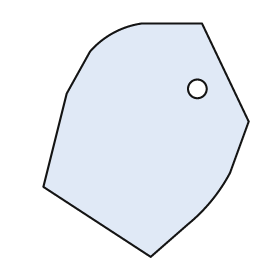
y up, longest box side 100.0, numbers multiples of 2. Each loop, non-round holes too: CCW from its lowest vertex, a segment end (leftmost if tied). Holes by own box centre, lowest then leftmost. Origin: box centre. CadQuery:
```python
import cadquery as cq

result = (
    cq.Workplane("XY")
    .moveTo(2.0, -50.0)
    .lineTo(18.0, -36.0)
    .threePointArc((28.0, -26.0), (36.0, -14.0))
    .lineTo(44.0, 8.0)
    .lineTo(24.0, 50.0)
    .lineTo(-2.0, 50.0)
    .threePointArc((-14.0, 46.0), (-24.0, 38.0))
    .lineTo(-34.0, 20.0)
    .lineTo(-44.0, -20.0)
    .close()
    .moveTo(22.0, 22.0)
    .circle(4.0)
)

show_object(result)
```